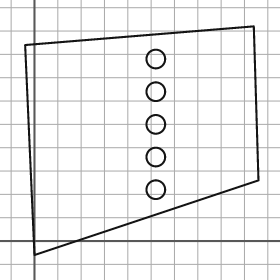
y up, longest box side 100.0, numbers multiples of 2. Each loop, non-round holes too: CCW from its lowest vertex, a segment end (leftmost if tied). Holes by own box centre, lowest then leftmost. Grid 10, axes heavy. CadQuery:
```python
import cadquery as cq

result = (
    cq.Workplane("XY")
    .moveTo(0.0, -6.0)
    .lineTo(96.0, 26.0)
    .lineTo(94.0, 92.0)
    .lineTo(-4.0, 84.0)
    .close()
    .moveTo(52.0, 22.0)
    .circle(4.0)
    .moveTo(52.0, 36.0)
    .circle(4.0)
    .moveTo(52.0, 50.0)
    .circle(4.0)
    .moveTo(52.0, 64.0)
    .circle(4.0)
    .moveTo(52.0, 78.0)
    .circle(4.0)
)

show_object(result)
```